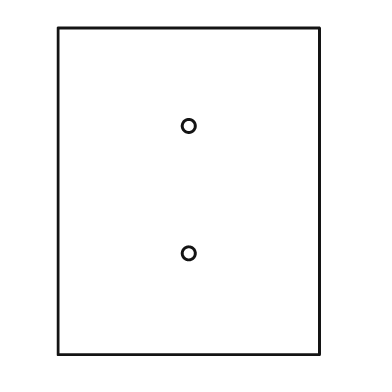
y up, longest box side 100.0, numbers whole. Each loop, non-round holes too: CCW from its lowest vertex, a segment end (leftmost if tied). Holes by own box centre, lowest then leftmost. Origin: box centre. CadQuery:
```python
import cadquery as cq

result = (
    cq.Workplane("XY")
    .moveTo(-40.0, -50.0)
    .lineTo(40.0, -50.0)
    .lineTo(40.0, 50.0)
    .lineTo(-40.0, 50.0)
    .close()
    .moveTo(0.0, -19.0)
    .circle(2.0)
    .moveTo(0.0, 20.0)
    .circle(2.0)
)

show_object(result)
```